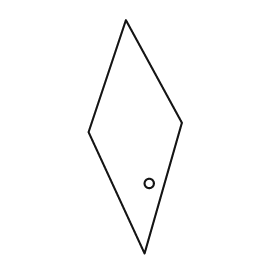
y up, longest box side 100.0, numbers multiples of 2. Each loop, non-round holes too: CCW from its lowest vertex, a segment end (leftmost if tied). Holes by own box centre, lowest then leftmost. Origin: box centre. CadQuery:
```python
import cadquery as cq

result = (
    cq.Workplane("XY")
    .moveTo(4.0, -50.0)
    .lineTo(20.0, 6.0)
    .lineTo(-4.0, 50.0)
    .lineTo(-20.0, 2.0)
    .close()
    .moveTo(6.0, -20.0)
    .circle(2.0)
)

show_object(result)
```